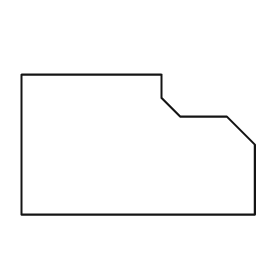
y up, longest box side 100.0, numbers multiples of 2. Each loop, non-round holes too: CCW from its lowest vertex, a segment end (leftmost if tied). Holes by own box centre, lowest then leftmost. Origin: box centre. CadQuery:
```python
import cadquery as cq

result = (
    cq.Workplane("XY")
    .moveTo(-50.0, -30.0)
    .lineTo(50.0, -30.0)
    .lineTo(50.0, 0.0)
    .lineTo(38.0, 12.0)
    .lineTo(18.0, 12.0)
    .lineTo(10.0, 20.0)
    .lineTo(10.0, 30.0)
    .lineTo(-50.0, 30.0)
    .close()
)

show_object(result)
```